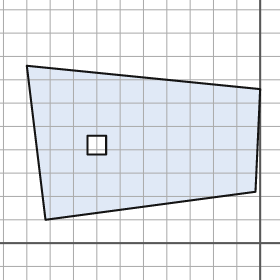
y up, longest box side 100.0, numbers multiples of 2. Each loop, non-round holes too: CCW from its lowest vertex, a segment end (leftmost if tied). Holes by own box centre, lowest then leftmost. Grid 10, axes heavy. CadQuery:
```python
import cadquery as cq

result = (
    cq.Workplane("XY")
    .moveTo(-92.0, 10.0)
    .lineTo(-2.0, 22.0)
    .lineTo(0.0, 66.0)
    .lineTo(-100.0, 76.0)
    .close()
    .moveTo(-74.0, 38.0)
    .lineTo(-66.0, 38.0)
    .lineTo(-66.0, 46.0)
    .lineTo(-74.0, 46.0)
    .close()
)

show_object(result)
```